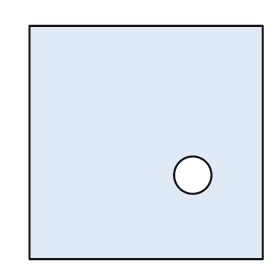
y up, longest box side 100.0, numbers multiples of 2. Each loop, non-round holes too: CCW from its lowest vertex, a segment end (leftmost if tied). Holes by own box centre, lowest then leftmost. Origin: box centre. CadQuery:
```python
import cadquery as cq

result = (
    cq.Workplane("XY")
    .moveTo(-50.0, -50.0)
    .lineTo(50.0, -50.0)
    .lineTo(50.0, 50.0)
    .lineTo(-50.0, 50.0)
    .close()
    .moveTo(20.0, -14.0)
    .circle(8.0)
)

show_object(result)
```